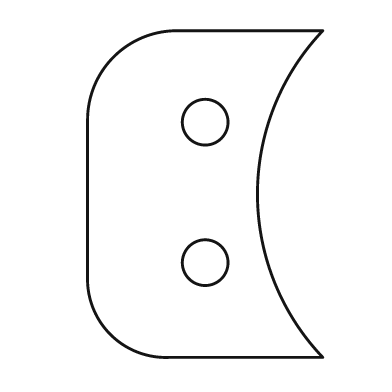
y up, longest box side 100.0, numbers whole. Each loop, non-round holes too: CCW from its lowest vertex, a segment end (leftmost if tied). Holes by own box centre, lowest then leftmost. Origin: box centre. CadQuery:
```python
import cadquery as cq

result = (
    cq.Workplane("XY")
    .moveTo(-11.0, -50.0)
    .lineTo(36.0, -50.0)
    .threePointArc((16.0, 0.0), (36.0, 50.0))
    .lineTo(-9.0, 50.0)
    .threePointArc((-28.0, 42.0), (-36.0, 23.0))
    .lineTo(-36.0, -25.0)
    .threePointArc((-29.0, -43.0), (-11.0, -50.0))
    .close()
    .moveTo(0.0, -21.0)
    .circle(7.0)
    .moveTo(0.0, 22.0)
    .circle(7.0)
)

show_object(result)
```